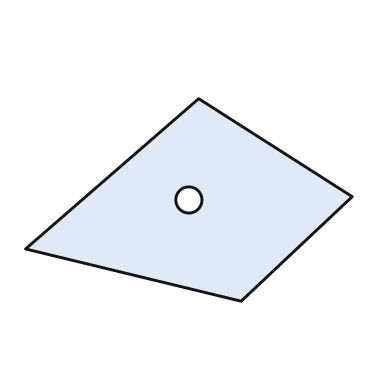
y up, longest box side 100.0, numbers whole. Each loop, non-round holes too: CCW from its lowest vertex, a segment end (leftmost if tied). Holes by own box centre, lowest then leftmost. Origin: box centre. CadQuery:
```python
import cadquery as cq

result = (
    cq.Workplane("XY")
    .moveTo(16.0, -31.0)
    .lineTo(50.0, 1.0)
    .lineTo(3.0, 31.0)
    .lineTo(-50.0, -15.0)
    .close()
    .moveTo(0.0, 0.0)
    .circle(4.0)
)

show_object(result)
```